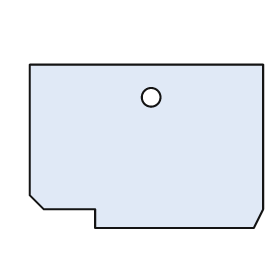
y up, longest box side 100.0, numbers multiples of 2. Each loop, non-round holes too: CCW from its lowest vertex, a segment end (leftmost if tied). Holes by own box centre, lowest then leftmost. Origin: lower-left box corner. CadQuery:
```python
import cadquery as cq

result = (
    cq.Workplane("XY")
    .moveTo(28.0, 0.0)
    .lineTo(96.0, 0.0)
    .lineTo(100.0, 8.0)
    .lineTo(100.0, 70.0)
    .lineTo(0.0, 70.0)
    .lineTo(0.0, 14.0)
    .lineTo(6.0, 8.0)
    .lineTo(28.0, 8.0)
    .close()
    .moveTo(52.0, 56.0)
    .circle(4.0)
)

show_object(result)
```